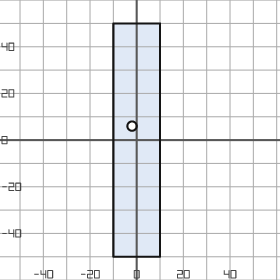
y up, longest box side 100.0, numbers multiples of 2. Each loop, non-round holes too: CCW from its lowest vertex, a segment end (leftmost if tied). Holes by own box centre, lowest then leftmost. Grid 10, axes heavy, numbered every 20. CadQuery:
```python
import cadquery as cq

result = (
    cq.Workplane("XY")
    .moveTo(-10.0, -50.0)
    .lineTo(10.0, -50.0)
    .lineTo(10.0, 50.0)
    .lineTo(-10.0, 50.0)
    .close()
    .moveTo(-2.0, 6.0)
    .circle(2.0)
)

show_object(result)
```